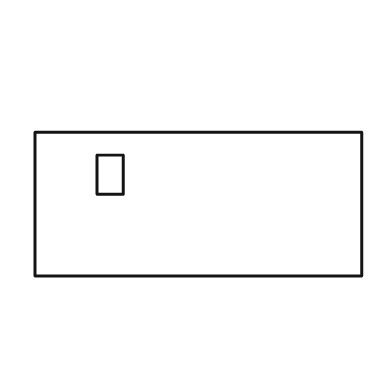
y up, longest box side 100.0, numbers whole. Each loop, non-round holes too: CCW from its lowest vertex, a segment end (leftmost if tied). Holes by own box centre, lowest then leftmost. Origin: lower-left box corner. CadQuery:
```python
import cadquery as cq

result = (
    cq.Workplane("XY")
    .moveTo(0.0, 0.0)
    .lineTo(100.0, 0.0)
    .lineTo(100.0, 44.0)
    .lineTo(0.0, 44.0)
    .close()
    .moveTo(19.0, 25.0)
    .lineTo(27.0, 25.0)
    .lineTo(27.0, 37.0)
    .lineTo(19.0, 37.0)
    .close()
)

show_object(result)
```